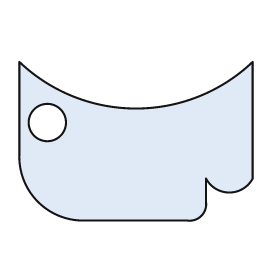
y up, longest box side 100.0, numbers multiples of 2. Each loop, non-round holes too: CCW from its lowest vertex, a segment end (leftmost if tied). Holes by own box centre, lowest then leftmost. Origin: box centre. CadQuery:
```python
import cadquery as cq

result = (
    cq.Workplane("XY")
    .moveTo(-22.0, -34.0)
    .lineTo(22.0, -34.0)
    .threePointArc((28.0, -32.0), (30.0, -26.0))
    .lineTo(30.0, -16.0)
    .threePointArc((40.0, -22.0), (50.0, -16.0))
    .lineTo(50.0, 34.0)
    .threePointArc((0.0, 14.0), (-50.0, 34.0))
    .lineTo(-50.0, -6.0)
    .threePointArc((-42.0, -26.0), (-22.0, -34.0))
    .close()
    .moveTo(-38.0, 8.0)
    .circle(8.0)
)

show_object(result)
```